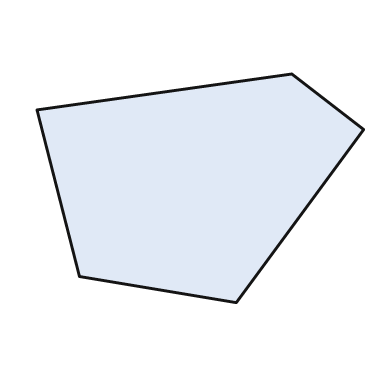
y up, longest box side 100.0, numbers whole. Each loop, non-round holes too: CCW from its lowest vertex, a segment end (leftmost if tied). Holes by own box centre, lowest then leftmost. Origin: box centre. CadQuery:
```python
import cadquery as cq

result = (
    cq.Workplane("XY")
    .moveTo(11.0, -35.0)
    .lineTo(50.0, 18.0)
    .lineTo(28.0, 35.0)
    .lineTo(-50.0, 24.0)
    .lineTo(-37.0, -27.0)
    .close()
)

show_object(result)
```